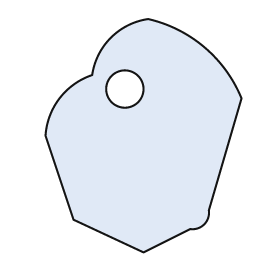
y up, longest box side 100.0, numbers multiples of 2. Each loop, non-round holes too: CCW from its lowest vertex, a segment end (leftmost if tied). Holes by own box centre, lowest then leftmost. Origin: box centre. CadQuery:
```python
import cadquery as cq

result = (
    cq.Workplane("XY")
    .moveTo(0.0, -50.0)
    .lineTo(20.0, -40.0)
    .threePointArc((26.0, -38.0), (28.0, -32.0))
    .lineTo(42.0, 16.0)
    .threePointArc((26.0, 38.0), (2.0, 50.0))
    .threePointArc((-14.0, 42.0), (-22.0, 26.0))
    .threePointArc((-36.0, 16.0), (-42.0, 0.0))
    .lineTo(-30.0, -36.0)
    .close()
    .moveTo(-8.0, 20.0)
    .circle(8.0)
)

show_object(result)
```